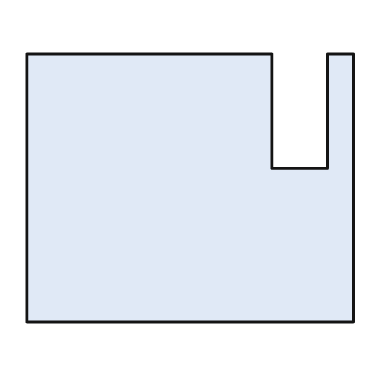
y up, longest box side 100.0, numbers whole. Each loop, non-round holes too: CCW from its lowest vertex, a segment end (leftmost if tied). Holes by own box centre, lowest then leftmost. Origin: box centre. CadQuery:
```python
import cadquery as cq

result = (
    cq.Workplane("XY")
    .moveTo(-50.0, -41.0)
    .lineTo(50.0, -41.0)
    .lineTo(50.0, 41.0)
    .lineTo(42.0, 41.0)
    .lineTo(42.0, 6.0)
    .lineTo(25.0, 6.0)
    .lineTo(25.0, 41.0)
    .lineTo(-50.0, 41.0)
    .close()
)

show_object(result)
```